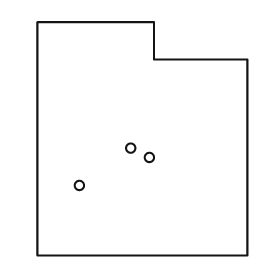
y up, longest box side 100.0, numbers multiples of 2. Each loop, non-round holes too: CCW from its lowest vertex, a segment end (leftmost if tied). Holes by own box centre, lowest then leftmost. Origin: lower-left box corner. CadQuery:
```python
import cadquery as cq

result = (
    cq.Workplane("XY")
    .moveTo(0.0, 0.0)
    .lineTo(90.0, 0.0)
    .lineTo(90.0, 84.0)
    .lineTo(50.0, 84.0)
    .lineTo(50.0, 100.0)
    .lineTo(0.0, 100.0)
    .close()
    .moveTo(18.0, 30.0)
    .circle(2.0)
    .moveTo(48.0, 42.0)
    .circle(2.0)
    .moveTo(40.0, 46.0)
    .circle(2.0)
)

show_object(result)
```